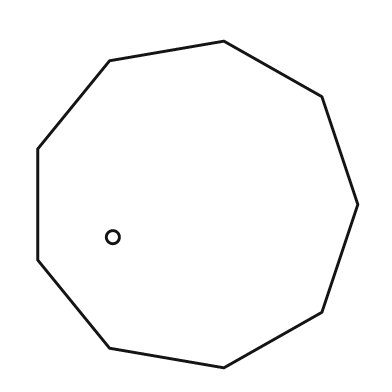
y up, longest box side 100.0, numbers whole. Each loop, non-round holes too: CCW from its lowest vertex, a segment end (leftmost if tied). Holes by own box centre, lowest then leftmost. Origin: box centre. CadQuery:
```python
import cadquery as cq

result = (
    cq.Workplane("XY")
    .moveTo(8.0, -50.0)
    .lineTo(38.0, -33.0)
    .lineTo(49.0, 0.0)
    .lineTo(38.0, 33.0)
    .lineTo(8.0, 50.0)
    .lineTo(-27.0, 44.0)
    .lineTo(-49.0, 17.0)
    .lineTo(-49.0, -17.0)
    .lineTo(-27.0, -44.0)
    .close()
    .moveTo(-26.0, -10.0)
    .circle(2.0)
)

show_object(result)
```